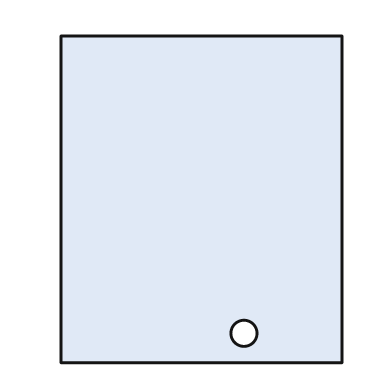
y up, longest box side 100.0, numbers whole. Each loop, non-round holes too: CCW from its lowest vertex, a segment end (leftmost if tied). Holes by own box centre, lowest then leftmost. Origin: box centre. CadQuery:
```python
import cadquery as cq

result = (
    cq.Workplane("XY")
    .moveTo(-43.0, -50.0)
    .lineTo(43.0, -50.0)
    .lineTo(43.0, 50.0)
    .lineTo(-43.0, 50.0)
    .close()
    .moveTo(13.0, -41.0)
    .circle(4.0)
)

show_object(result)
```